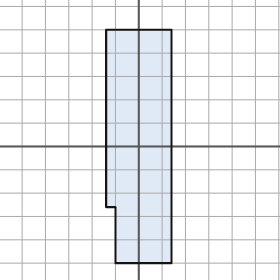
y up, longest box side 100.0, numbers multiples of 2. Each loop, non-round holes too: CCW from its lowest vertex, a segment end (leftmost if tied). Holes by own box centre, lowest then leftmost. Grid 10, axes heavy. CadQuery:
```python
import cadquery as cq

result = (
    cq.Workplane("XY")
    .moveTo(-10.0, -50.0)
    .lineTo(14.0, -50.0)
    .lineTo(14.0, 50.0)
    .lineTo(-14.0, 50.0)
    .lineTo(-14.0, -26.0)
    .lineTo(-10.0, -26.0)
    .close()
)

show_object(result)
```